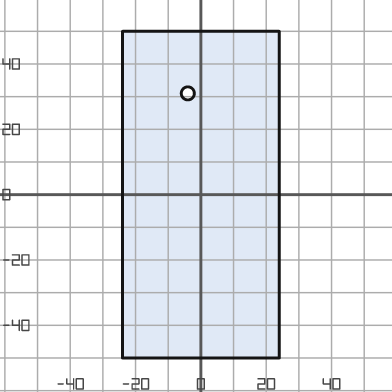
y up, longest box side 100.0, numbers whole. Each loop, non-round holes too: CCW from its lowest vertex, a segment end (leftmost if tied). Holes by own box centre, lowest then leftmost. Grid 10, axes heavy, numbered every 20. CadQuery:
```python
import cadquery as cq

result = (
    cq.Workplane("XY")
    .moveTo(-24.0, -50.0)
    .lineTo(24.0, -50.0)
    .lineTo(24.0, 50.0)
    .lineTo(-24.0, 50.0)
    .close()
    .moveTo(-4.0, 31.0)
    .circle(2.0)
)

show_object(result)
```